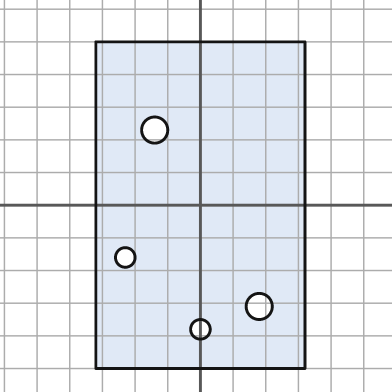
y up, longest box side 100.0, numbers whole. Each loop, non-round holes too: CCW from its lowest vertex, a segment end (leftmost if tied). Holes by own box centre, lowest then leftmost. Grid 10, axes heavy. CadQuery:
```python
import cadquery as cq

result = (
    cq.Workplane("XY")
    .moveTo(-32.0, -50.0)
    .lineTo(32.0, -50.0)
    .lineTo(32.0, 50.0)
    .lineTo(-32.0, 50.0)
    .close()
    .moveTo(0.0, -38.0)
    .circle(3.0)
    .moveTo(18.0, -31.0)
    .circle(4.0)
    .moveTo(-23.0, -16.0)
    .circle(3.0)
    .moveTo(-14.0, 23.0)
    .circle(4.0)
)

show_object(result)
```